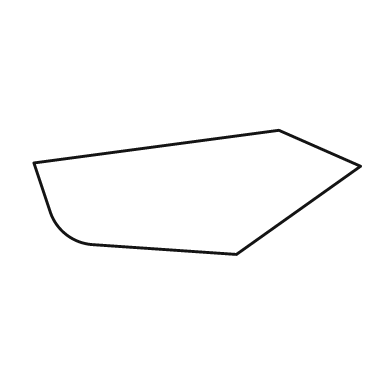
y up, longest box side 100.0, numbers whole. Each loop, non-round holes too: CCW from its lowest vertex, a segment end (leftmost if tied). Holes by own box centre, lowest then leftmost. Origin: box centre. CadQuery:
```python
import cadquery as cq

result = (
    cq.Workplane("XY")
    .moveTo(12.0, -19.0)
    .lineTo(50.0, 8.0)
    .lineTo(25.0, 19.0)
    .lineTo(-50.0, 9.0)
    .lineTo(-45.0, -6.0)
    .threePointArc((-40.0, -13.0), (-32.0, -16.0))
    .close()
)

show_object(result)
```